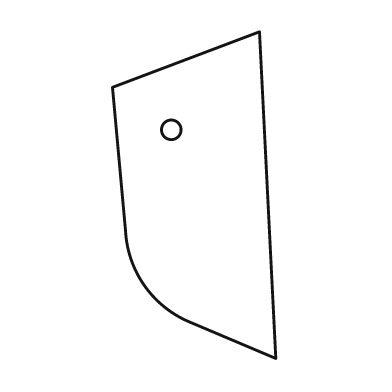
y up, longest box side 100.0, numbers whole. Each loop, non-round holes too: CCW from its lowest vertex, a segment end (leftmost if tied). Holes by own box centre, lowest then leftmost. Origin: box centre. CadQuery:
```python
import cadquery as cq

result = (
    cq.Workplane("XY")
    .moveTo(25.0, -50.0)
    .lineTo(20.0, 50.0)
    .lineTo(-25.0, 33.0)
    .lineTo(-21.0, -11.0)
    .threePointArc((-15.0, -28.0), (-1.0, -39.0))
    .close()
    .moveTo(-7.0, 20.0)
    .circle(3.0)
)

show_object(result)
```